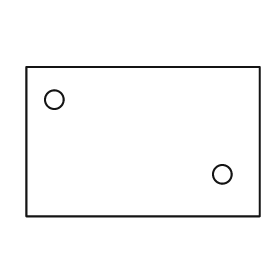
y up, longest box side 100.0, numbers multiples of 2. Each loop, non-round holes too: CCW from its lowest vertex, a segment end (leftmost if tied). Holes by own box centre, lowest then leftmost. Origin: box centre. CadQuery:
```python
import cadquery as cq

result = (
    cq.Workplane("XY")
    .moveTo(-50.0, -32.0)
    .lineTo(50.0, -32.0)
    .lineTo(50.0, 32.0)
    .lineTo(-50.0, 32.0)
    .close()
    .moveTo(34.0, -14.0)
    .circle(4.0)
    .moveTo(-38.0, 18.0)
    .circle(4.0)
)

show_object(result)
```